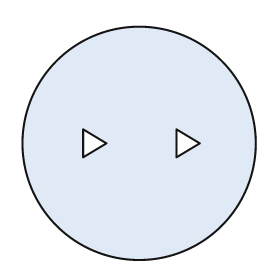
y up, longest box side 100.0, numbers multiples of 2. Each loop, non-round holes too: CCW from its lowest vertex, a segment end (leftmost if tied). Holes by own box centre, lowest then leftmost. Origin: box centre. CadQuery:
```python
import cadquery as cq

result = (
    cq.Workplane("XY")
    .moveTo(0.0, 0.0)
    .circle(50.0)
    .moveTo(-24.0, -6.0)
    .lineTo(-14.0, 0.0)
    .lineTo(-24.0, 6.0)
    .close()
    .moveTo(16.0, -6.0)
    .lineTo(26.0, 0.0)
    .lineTo(16.0, 6.0)
    .close()
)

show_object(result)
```